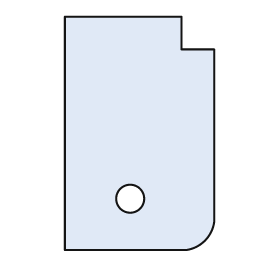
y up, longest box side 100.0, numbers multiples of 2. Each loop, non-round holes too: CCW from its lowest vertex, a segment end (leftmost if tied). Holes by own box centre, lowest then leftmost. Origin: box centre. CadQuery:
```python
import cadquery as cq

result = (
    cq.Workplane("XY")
    .moveTo(-32.0, -50.0)
    .lineTo(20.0, -50.0)
    .threePointArc((28.0, -46.0), (32.0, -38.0))
    .lineTo(32.0, 36.0)
    .lineTo(18.0, 36.0)
    .lineTo(18.0, 50.0)
    .lineTo(-32.0, 50.0)
    .close()
    .moveTo(-4.0, -28.0)
    .circle(6.0)
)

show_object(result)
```